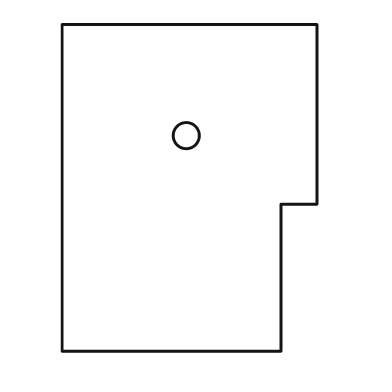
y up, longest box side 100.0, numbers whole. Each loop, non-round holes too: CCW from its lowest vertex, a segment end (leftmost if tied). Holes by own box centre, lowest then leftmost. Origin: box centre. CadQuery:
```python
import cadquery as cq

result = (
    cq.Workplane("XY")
    .moveTo(-39.0, -50.0)
    .lineTo(28.0, -50.0)
    .lineTo(28.0, -5.0)
    .lineTo(39.0, -5.0)
    .lineTo(39.0, 50.0)
    .lineTo(-39.0, 50.0)
    .close()
    .moveTo(-1.0, 16.0)
    .circle(4.0)
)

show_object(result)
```